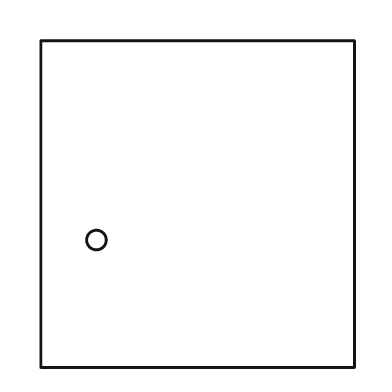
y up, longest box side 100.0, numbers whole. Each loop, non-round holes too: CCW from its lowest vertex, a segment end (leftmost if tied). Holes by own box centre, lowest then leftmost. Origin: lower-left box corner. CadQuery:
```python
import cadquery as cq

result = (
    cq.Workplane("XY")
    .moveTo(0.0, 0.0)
    .lineTo(96.0, 0.0)
    .lineTo(96.0, 100.0)
    .lineTo(0.0, 100.0)
    .close()
    .moveTo(17.0, 39.0)
    .circle(3.0)
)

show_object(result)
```